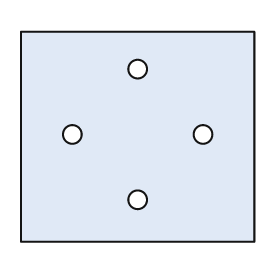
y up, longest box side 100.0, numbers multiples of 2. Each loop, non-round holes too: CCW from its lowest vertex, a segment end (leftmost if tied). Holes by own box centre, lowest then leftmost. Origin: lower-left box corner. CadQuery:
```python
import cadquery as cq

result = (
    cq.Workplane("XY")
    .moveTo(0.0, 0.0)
    .lineTo(100.0, 0.0)
    .lineTo(100.0, 90.0)
    .lineTo(0.0, 90.0)
    .close()
    .moveTo(50.0, 18.0)
    .circle(4.0)
    .moveTo(22.0, 46.0)
    .circle(4.0)
    .moveTo(78.0, 46.0)
    .circle(4.0)
    .moveTo(50.0, 74.0)
    .circle(4.0)
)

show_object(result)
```